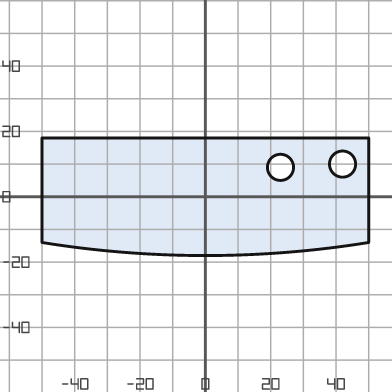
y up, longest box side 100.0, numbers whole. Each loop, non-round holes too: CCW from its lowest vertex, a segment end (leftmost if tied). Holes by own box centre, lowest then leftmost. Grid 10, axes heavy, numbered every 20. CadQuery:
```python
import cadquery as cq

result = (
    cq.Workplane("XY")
    .moveTo(-50.0, -14.0)
    .threePointArc((0.0, -18.0), (50.0, -14.0))
    .lineTo(50.0, 18.0)
    .lineTo(-50.0, 18.0)
    .close()
    .moveTo(23.0, 9.0)
    .circle(4.0)
    .moveTo(42.0, 10.0)
    .circle(4.0)
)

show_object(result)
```